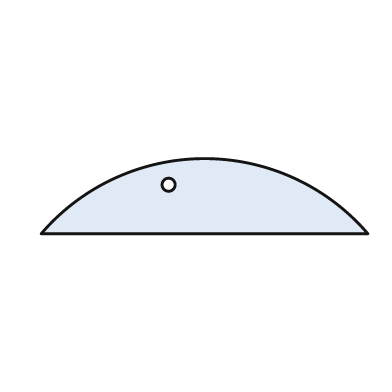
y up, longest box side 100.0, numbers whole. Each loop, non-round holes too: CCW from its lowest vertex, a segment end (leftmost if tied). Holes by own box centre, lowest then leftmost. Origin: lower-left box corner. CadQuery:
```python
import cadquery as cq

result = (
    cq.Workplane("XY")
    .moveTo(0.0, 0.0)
    .lineTo(100.0, 0.0)
    .threePointArc((50.0, 23.0), (0.0, 0.0))
    .close()
    .moveTo(39.0, 15.0)
    .circle(2.0)
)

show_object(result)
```